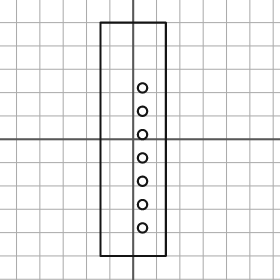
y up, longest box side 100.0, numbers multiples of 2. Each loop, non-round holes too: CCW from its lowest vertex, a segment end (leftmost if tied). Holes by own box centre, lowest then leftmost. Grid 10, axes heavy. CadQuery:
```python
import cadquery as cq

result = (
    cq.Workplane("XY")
    .moveTo(-14.0, -50.0)
    .lineTo(14.0, -50.0)
    .lineTo(14.0, 50.0)
    .lineTo(-14.0, 50.0)
    .close()
    .moveTo(4.0, -38.0)
    .circle(2.0)
    .moveTo(4.0, -28.0)
    .circle(2.0)
    .moveTo(4.0, -18.0)
    .circle(2.0)
    .moveTo(4.0, -8.0)
    .circle(2.0)
    .moveTo(4.0, 2.0)
    .circle(2.0)
    .moveTo(4.0, 12.0)
    .circle(2.0)
    .moveTo(4.0, 22.0)
    .circle(2.0)
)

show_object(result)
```